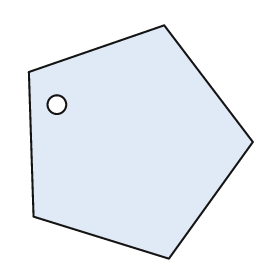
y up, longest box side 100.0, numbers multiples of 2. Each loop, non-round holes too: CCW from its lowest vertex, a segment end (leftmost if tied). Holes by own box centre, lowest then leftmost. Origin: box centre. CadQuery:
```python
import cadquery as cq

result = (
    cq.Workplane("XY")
    .moveTo(12.0, -50.0)
    .lineTo(48.0, 0.0)
    .lineTo(10.0, 50.0)
    .lineTo(-48.0, 30.0)
    .lineTo(-46.0, -32.0)
    .close()
    .moveTo(-36.0, 16.0)
    .circle(4.0)
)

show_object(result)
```